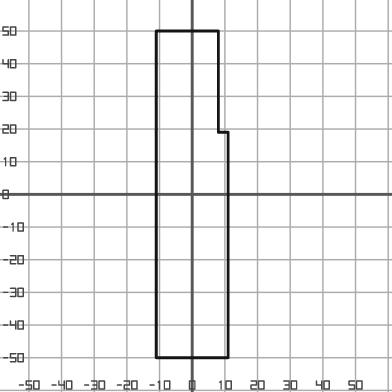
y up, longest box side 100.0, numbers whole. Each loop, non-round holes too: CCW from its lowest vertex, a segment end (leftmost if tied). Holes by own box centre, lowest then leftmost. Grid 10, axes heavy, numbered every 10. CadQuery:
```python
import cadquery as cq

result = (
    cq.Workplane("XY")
    .moveTo(-11.0, -50.0)
    .lineTo(11.0, -50.0)
    .lineTo(11.0, 19.0)
    .lineTo(8.0, 19.0)
    .lineTo(8.0, 50.0)
    .lineTo(-11.0, 50.0)
    .close()
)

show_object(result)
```